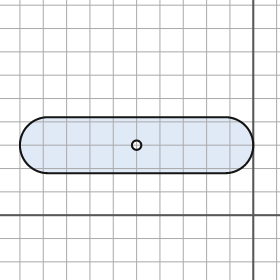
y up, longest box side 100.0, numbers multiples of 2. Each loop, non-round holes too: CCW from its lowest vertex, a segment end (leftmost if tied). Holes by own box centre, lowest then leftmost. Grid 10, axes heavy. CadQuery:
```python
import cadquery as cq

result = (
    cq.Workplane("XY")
    .moveTo(-88.0, 18.0)
    .lineTo(-12.0, 18.0)
    .threePointArc((0.0, 30.0), (-12.0, 42.0))
    .lineTo(-88.0, 42.0)
    .threePointArc((-100.0, 30.0), (-88.0, 18.0))
    .close()
    .moveTo(-50.0, 30.0)
    .circle(2.0)
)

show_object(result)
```